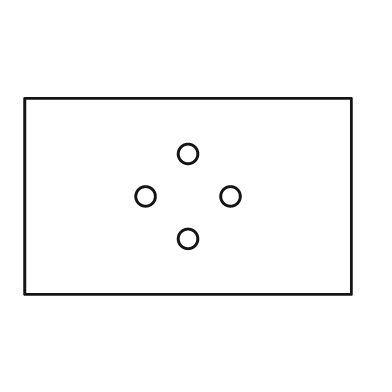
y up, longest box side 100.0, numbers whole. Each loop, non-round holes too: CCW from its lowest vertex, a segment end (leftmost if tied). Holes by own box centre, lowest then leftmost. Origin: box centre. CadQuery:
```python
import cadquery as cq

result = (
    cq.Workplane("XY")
    .moveTo(-50.0, -30.0)
    .lineTo(50.0, -30.0)
    .lineTo(50.0, 30.0)
    .lineTo(-50.0, 30.0)
    .close()
    .moveTo(0.0, -13.0)
    .circle(3.0)
    .moveTo(-13.0, 0.0)
    .circle(3.0)
    .moveTo(13.0, 0.0)
    .circle(3.0)
    .moveTo(0.0, 13.0)
    .circle(3.0)
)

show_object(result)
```